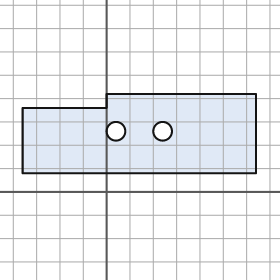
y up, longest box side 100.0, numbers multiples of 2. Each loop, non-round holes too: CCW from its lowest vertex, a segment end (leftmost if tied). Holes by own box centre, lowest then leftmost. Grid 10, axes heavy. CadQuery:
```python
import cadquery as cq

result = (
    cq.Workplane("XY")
    .moveTo(-36.0, 8.0)
    .lineTo(64.0, 8.0)
    .lineTo(64.0, 42.0)
    .lineTo(0.0, 42.0)
    .lineTo(0.0, 36.0)
    .lineTo(-36.0, 36.0)
    .close()
    .moveTo(4.0, 26.0)
    .circle(4.0)
    .moveTo(24.0, 26.0)
    .circle(4.0)
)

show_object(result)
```